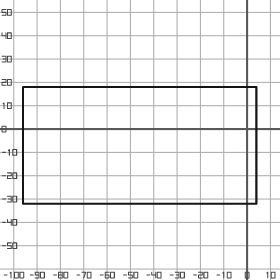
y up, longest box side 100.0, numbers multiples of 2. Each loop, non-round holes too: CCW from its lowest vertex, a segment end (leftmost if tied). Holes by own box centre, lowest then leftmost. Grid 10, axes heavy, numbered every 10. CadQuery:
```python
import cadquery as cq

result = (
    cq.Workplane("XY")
    .moveTo(-96.0, -32.0)
    .lineTo(4.0, -32.0)
    .lineTo(4.0, 18.0)
    .lineTo(-96.0, 18.0)
    .close()
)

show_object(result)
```